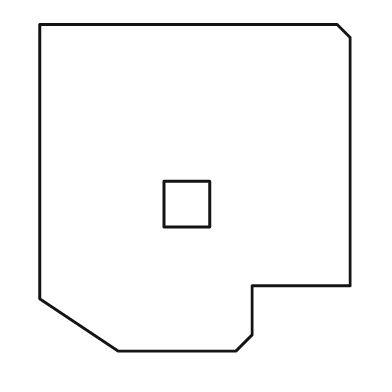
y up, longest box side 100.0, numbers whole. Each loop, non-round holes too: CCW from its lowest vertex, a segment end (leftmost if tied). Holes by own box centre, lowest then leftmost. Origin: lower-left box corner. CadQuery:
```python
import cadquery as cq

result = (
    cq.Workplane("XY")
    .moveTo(24.0, 0.0)
    .lineTo(60.0, 0.0)
    .lineTo(65.0, 5.0)
    .lineTo(65.0, 20.0)
    .lineTo(95.0, 20.0)
    .lineTo(95.0, 96.0)
    .lineTo(91.0, 100.0)
    .lineTo(0.0, 100.0)
    .lineTo(0.0, 16.0)
    .close()
    .moveTo(38.0, 38.0)
    .lineTo(52.0, 38.0)
    .lineTo(52.0, 52.0)
    .lineTo(38.0, 52.0)
    .close()
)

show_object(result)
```